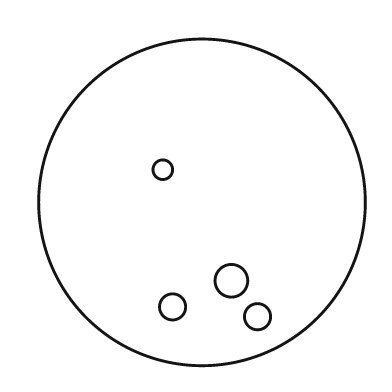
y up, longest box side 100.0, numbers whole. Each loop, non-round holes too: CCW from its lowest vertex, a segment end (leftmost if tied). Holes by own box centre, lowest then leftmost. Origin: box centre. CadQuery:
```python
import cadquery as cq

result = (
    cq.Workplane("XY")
    .moveTo(0.0, 0.0)
    .circle(50.0)
    .moveTo(17.0, -35.0)
    .circle(4.0)
    .moveTo(-9.0, -32.0)
    .circle(4.0)
    .moveTo(9.0, -24.0)
    .circle(5.0)
    .moveTo(-12.0, 10.0)
    .circle(3.0)
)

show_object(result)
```